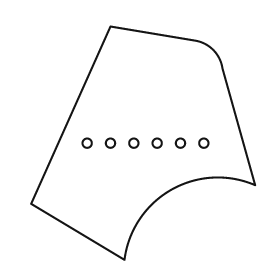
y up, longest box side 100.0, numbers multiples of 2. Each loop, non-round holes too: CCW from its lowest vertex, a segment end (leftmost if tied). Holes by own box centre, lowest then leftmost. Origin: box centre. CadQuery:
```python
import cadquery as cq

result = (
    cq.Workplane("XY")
    .moveTo(-8.0, -50.0)
    .threePointArc((12.0, -20.0), (48.0, -18.0))
    .lineTo(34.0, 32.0)
    .threePointArc((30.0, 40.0), (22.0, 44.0))
    .lineTo(-14.0, 50.0)
    .lineTo(-48.0, -26.0)
    .close()
    .moveTo(-24.0, 0.0)
    .circle(2.0)
    .moveTo(-14.0, 0.0)
    .circle(2.0)
    .moveTo(-4.0, 0.0)
    .circle(2.0)
    .moveTo(6.0, 0.0)
    .circle(2.0)
    .moveTo(16.0, 0.0)
    .circle(2.0)
    .moveTo(26.0, 0.0)
    .circle(2.0)
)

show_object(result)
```